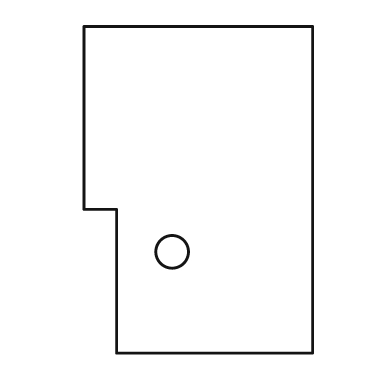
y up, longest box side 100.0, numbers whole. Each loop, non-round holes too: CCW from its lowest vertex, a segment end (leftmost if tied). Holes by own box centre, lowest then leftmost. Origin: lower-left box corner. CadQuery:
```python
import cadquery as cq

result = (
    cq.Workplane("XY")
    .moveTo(10.0, 0.0)
    .lineTo(70.0, 0.0)
    .lineTo(70.0, 100.0)
    .lineTo(0.0, 100.0)
    .lineTo(0.0, 44.0)
    .lineTo(10.0, 44.0)
    .close()
    .moveTo(27.0, 31.0)
    .circle(5.0)
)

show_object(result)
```